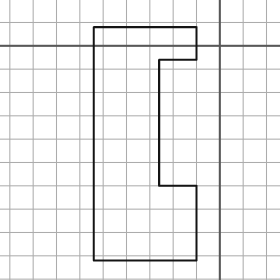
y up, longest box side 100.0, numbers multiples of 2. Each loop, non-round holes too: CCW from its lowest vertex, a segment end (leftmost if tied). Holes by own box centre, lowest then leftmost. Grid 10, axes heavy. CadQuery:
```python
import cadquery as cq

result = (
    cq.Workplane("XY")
    .moveTo(-54.0, -92.0)
    .lineTo(-10.0, -92.0)
    .lineTo(-10.0, -60.0)
    .lineTo(-26.0, -60.0)
    .lineTo(-26.0, -6.0)
    .lineTo(-10.0, -6.0)
    .lineTo(-10.0, 8.0)
    .lineTo(-54.0, 8.0)
    .close()
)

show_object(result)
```